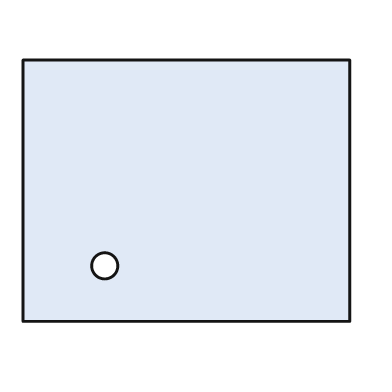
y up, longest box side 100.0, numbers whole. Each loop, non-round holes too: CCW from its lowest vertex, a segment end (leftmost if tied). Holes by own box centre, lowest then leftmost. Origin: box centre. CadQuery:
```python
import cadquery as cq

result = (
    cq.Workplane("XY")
    .moveTo(-50.0, -40.0)
    .lineTo(50.0, -40.0)
    .lineTo(50.0, 40.0)
    .lineTo(-50.0, 40.0)
    .close()
    .moveTo(-25.0, -23.0)
    .circle(4.0)
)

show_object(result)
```